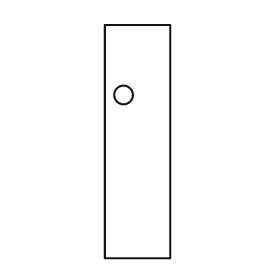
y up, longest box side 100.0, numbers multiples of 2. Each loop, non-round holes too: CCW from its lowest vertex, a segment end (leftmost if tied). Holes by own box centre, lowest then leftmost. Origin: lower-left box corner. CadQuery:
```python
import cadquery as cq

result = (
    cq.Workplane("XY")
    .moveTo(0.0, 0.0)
    .lineTo(28.0, 0.0)
    .lineTo(28.0, 100.0)
    .lineTo(0.0, 100.0)
    .close()
    .moveTo(8.0, 70.0)
    .circle(4.0)
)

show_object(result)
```